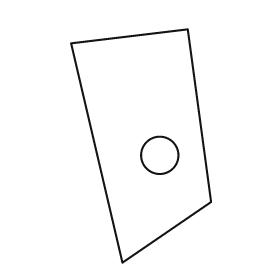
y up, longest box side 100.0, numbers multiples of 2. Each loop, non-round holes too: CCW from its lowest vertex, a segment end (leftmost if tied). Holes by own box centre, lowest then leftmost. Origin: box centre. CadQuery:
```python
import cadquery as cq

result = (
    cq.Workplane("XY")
    .moveTo(-8.0, -50.0)
    .lineTo(30.0, -24.0)
    .lineTo(20.0, 50.0)
    .lineTo(-30.0, 44.0)
    .close()
    .moveTo(8.0, -4.0)
    .circle(8.0)
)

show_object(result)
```